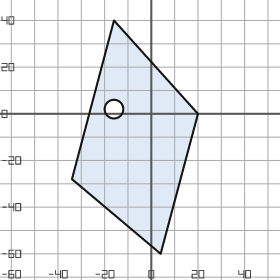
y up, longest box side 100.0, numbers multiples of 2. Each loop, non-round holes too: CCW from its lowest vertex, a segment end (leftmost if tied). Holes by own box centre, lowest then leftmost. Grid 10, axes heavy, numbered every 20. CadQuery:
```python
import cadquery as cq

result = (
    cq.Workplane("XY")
    .moveTo(4.0, -60.0)
    .lineTo(20.0, 0.0)
    .lineTo(-16.0, 40.0)
    .lineTo(-34.0, -28.0)
    .close()
    .moveTo(-16.0, 2.0)
    .circle(4.0)
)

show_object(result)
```